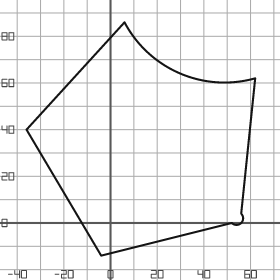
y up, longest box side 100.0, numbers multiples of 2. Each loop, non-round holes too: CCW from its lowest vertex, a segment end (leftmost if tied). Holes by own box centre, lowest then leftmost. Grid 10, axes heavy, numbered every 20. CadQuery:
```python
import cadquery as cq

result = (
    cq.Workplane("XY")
    .moveTo(-4.0, -14.0)
    .lineTo(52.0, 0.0)
    .threePointArc((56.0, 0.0), (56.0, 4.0))
    .lineTo(62.0, 62.0)
    .threePointArc((30.0, 64.0), (6.0, 86.0))
    .lineTo(-36.0, 40.0)
    .close()
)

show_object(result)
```